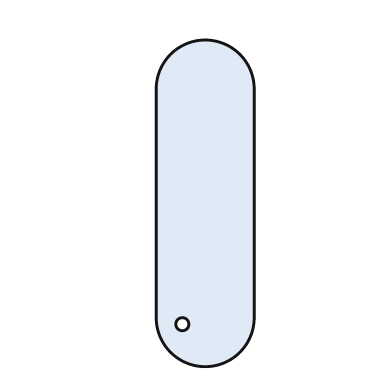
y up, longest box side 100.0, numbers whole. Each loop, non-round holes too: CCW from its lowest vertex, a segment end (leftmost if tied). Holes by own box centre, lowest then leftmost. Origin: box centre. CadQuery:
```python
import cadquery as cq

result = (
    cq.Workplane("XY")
    .moveTo(-15.0, -35.0)
    .threePointArc((0.0, -50.0), (15.0, -35.0))
    .lineTo(15.0, 35.0)
    .threePointArc((0.0, 50.0), (-15.0, 35.0))
    .close()
    .moveTo(-7.0, -37.0)
    .circle(2.0)
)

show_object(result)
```